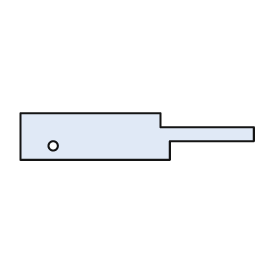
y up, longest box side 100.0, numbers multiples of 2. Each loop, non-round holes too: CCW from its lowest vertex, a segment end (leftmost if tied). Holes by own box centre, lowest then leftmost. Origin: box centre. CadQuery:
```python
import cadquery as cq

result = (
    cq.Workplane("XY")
    .moveTo(-50.0, -10.0)
    .lineTo(14.0, -10.0)
    .lineTo(14.0, -2.0)
    .lineTo(50.0, -2.0)
    .lineTo(50.0, 4.0)
    .lineTo(10.0, 4.0)
    .lineTo(10.0, 10.0)
    .lineTo(-50.0, 10.0)
    .close()
    .moveTo(-36.0, -4.0)
    .circle(2.0)
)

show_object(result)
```